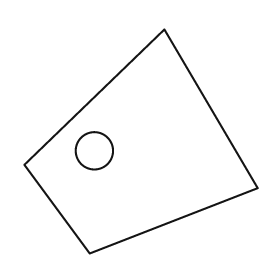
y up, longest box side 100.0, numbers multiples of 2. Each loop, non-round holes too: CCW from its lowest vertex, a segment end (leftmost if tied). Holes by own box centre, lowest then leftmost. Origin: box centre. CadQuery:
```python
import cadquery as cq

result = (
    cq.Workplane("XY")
    .moveTo(-22.0, -48.0)
    .lineTo(50.0, -20.0)
    .lineTo(10.0, 48.0)
    .lineTo(-50.0, -10.0)
    .close()
    .moveTo(-20.0, -4.0)
    .circle(8.0)
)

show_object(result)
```